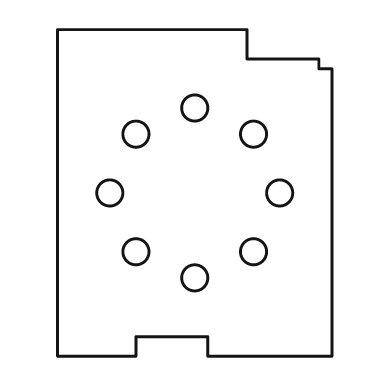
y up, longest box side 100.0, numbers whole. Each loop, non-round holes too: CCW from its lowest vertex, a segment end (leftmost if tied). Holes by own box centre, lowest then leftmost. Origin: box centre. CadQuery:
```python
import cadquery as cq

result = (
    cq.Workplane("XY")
    .moveTo(-42.0, -50.0)
    .lineTo(-18.0, -50.0)
    .lineTo(-18.0, -44.0)
    .lineTo(4.0, -44.0)
    .lineTo(4.0, -50.0)
    .lineTo(42.0, -50.0)
    .lineTo(42.0, 38.0)
    .lineTo(38.0, 38.0)
    .lineTo(38.0, 41.0)
    .lineTo(16.0, 41.0)
    .lineTo(16.0, 50.0)
    .lineTo(-42.0, 50.0)
    .close()
    .moveTo(0.0, -26.0)
    .circle(4.0)
    .moveTo(-18.0, -18.0)
    .circle(4.0)
    .moveTo(18.0, -18.0)
    .circle(4.0)
    .moveTo(-26.0, 0.0)
    .circle(4.0)
    .moveTo(26.0, 0.0)
    .circle(4.0)
    .moveTo(-18.0, 18.0)
    .circle(4.0)
    .moveTo(18.0, 18.0)
    .circle(4.0)
    .moveTo(0.0, 26.0)
    .circle(4.0)
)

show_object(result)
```